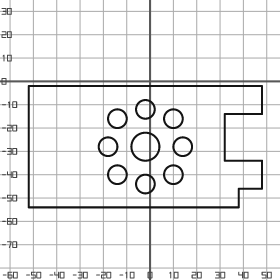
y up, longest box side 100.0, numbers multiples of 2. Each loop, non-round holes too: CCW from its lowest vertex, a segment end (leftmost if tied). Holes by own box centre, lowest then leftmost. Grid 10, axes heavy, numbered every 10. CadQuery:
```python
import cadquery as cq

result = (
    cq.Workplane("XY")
    .moveTo(-52.0, -54.0)
    .lineTo(38.0, -54.0)
    .lineTo(38.0, -46.0)
    .lineTo(48.0, -46.0)
    .lineTo(48.0, -34.0)
    .lineTo(32.0, -34.0)
    .lineTo(32.0, -14.0)
    .lineTo(48.0, -14.0)
    .lineTo(48.0, -2.0)
    .lineTo(-52.0, -2.0)
    .close()
    .moveTo(-2.0, -44.0)
    .circle(4.0)
    .moveTo(-14.0, -40.0)
    .circle(4.0)
    .moveTo(10.0, -40.0)
    .circle(4.0)
    .moveTo(-18.0, -28.0)
    .circle(4.0)
    .moveTo(-2.0, -28.0)
    .circle(6.0)
    .moveTo(14.0, -28.0)
    .circle(4.0)
    .moveTo(-14.0, -16.0)
    .circle(4.0)
    .moveTo(10.0, -16.0)
    .circle(4.0)
    .moveTo(-2.0, -12.0)
    .circle(4.0)
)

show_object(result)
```